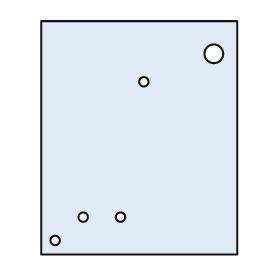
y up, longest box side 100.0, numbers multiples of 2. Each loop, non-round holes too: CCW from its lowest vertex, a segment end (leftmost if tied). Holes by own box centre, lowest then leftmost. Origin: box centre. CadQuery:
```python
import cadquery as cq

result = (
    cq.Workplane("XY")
    .moveTo(-42.0, -50.0)
    .lineTo(42.0, -50.0)
    .lineTo(42.0, 50.0)
    .lineTo(-42.0, 50.0)
    .close()
    .moveTo(-36.0, -44.0)
    .circle(2.0)
    .moveTo(-24.0, -34.0)
    .circle(2.0)
    .moveTo(-8.0, -34.0)
    .circle(2.0)
    .moveTo(2.0, 24.0)
    .circle(2.0)
    .moveTo(32.0, 36.0)
    .circle(4.0)
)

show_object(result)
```